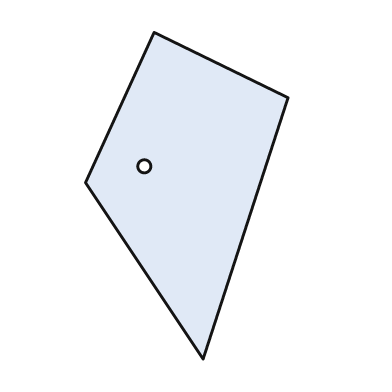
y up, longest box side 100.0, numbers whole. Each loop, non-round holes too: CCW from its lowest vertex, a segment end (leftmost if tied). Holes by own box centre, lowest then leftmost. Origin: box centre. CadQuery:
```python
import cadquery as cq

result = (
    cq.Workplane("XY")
    .moveTo(5.0, -50.0)
    .lineTo(31.0, 30.0)
    .lineTo(-10.0, 50.0)
    .lineTo(-31.0, 4.0)
    .close()
    .moveTo(-13.0, 9.0)
    .circle(2.0)
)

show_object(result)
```